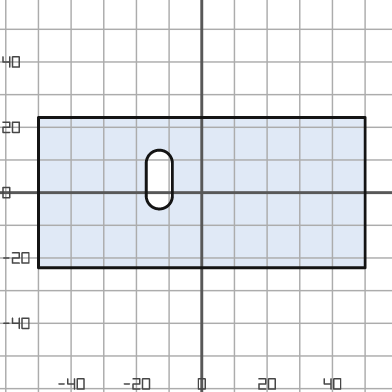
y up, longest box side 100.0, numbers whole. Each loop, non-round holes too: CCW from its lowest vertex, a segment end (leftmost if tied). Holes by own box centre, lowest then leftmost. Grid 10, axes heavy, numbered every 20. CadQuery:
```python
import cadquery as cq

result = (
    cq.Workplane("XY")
    .moveTo(-50.0, -23.0)
    .lineTo(50.0, -23.0)
    .lineTo(50.0, 23.0)
    .lineTo(-50.0, 23.0)
    .close()
    .moveTo(-17.0, -1.0)
    .threePointArc((-13.0, -5.0), (-9.0, -1.0))
    .lineTo(-9.0, 9.0)
    .threePointArc((-13.0, 13.0), (-17.0, 9.0))
    .close()
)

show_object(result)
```